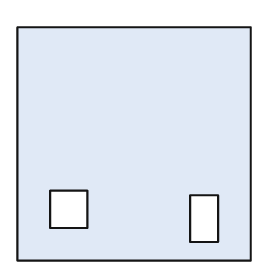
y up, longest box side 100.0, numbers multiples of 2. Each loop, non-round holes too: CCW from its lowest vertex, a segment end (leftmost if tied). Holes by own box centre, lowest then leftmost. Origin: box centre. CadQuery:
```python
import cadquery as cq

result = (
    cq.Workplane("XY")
    .moveTo(-50.0, -50.0)
    .lineTo(50.0, -50.0)
    .lineTo(50.0, 50.0)
    .lineTo(-50.0, 50.0)
    .close()
    .moveTo(24.0, -42.0)
    .lineTo(36.0, -42.0)
    .lineTo(36.0, -22.0)
    .lineTo(24.0, -22.0)
    .close()
    .moveTo(-36.0, -36.0)
    .lineTo(-20.0, -36.0)
    .lineTo(-20.0, -20.0)
    .lineTo(-36.0, -20.0)
    .close()
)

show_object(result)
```